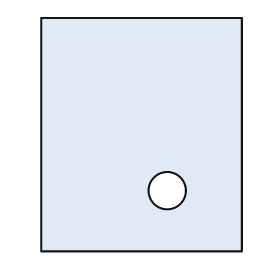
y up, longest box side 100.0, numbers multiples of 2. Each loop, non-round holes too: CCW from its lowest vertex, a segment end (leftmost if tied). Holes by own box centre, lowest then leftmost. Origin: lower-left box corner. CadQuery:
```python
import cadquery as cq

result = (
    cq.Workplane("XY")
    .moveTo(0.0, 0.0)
    .lineTo(86.0, 0.0)
    .lineTo(86.0, 100.0)
    .lineTo(0.0, 100.0)
    .close()
    .moveTo(54.0, 26.0)
    .circle(8.0)
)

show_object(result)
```